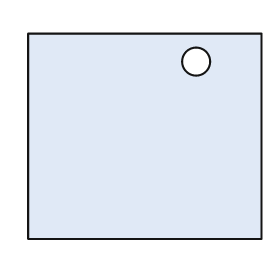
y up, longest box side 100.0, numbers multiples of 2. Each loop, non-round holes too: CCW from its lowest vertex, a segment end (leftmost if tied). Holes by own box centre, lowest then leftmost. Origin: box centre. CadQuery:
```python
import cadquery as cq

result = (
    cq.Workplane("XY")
    .moveTo(-50.0, -44.0)
    .lineTo(50.0, -44.0)
    .lineTo(50.0, 44.0)
    .lineTo(-50.0, 44.0)
    .close()
    .moveTo(22.0, 32.0)
    .circle(6.0)
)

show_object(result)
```